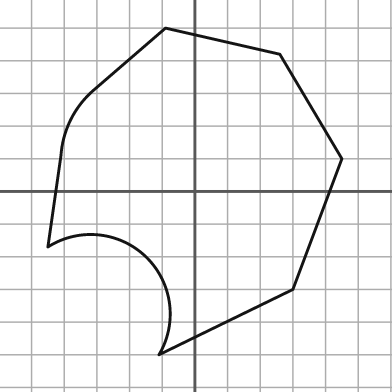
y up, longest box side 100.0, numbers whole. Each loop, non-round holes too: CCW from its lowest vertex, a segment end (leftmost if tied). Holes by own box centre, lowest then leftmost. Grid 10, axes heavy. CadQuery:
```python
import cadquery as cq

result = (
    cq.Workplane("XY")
    .moveTo(-11.0, -50.0)
    .lineTo(30.0, -30.0)
    .lineTo(45.0, 10.0)
    .lineTo(26.0, 42.0)
    .lineTo(-9.0, 50.0)
    .lineTo(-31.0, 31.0)
    .threePointArc((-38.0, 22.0), (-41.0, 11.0))
    .lineTo(-45.0, -17.0)
    .threePointArc((-15.0, -20.0), (-11.0, -50.0))
    .close()
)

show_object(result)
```